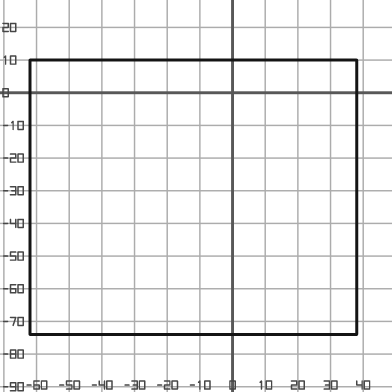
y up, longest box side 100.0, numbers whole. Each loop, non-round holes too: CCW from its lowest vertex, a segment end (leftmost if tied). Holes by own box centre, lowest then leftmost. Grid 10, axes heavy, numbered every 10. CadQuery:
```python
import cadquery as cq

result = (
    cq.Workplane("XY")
    .moveTo(-62.0, -74.0)
    .lineTo(38.0, -74.0)
    .lineTo(38.0, 10.0)
    .lineTo(-62.0, 10.0)
    .close()
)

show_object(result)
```